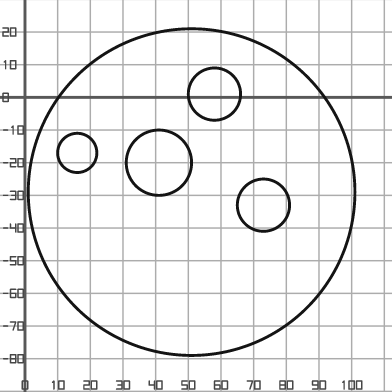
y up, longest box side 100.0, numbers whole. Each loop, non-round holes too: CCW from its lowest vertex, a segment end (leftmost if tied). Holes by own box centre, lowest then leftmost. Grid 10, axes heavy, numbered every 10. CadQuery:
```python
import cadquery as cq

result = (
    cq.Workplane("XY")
    .moveTo(51.0, -29.0)
    .circle(50.0)
    .moveTo(73.0, -33.0)
    .circle(8.0)
    .moveTo(41.0, -20.0)
    .circle(10.0)
    .moveTo(16.0, -17.0)
    .circle(6.0)
    .moveTo(58.0, 1.0)
    .circle(8.0)
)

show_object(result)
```